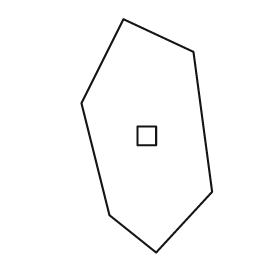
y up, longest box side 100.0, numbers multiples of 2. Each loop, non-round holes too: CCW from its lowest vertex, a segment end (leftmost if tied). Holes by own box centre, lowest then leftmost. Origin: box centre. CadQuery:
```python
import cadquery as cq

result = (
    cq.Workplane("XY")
    .moveTo(4.0, -50.0)
    .lineTo(28.0, -24.0)
    .lineTo(20.0, 36.0)
    .lineTo(-10.0, 50.0)
    .lineTo(-28.0, 14.0)
    .lineTo(-16.0, -34.0)
    .close()
    .moveTo(-4.0, -4.0)
    .lineTo(4.0, -4.0)
    .lineTo(4.0, 4.0)
    .lineTo(-4.0, 4.0)
    .close()
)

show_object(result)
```